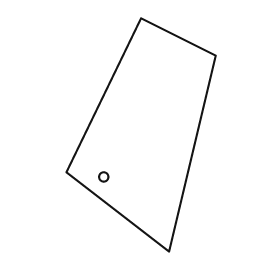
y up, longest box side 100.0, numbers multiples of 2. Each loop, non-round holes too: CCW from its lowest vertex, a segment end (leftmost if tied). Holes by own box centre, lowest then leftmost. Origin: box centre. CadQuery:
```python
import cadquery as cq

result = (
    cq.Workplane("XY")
    .moveTo(12.0, -50.0)
    .lineTo(32.0, 34.0)
    .lineTo(0.0, 50.0)
    .lineTo(-32.0, -16.0)
    .close()
    .moveTo(-16.0, -18.0)
    .circle(2.0)
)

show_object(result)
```